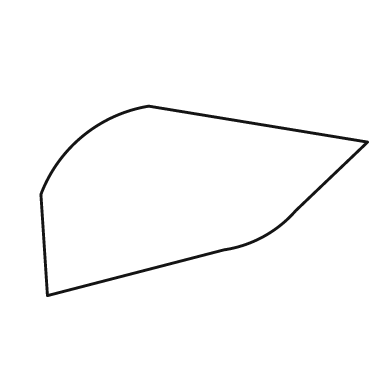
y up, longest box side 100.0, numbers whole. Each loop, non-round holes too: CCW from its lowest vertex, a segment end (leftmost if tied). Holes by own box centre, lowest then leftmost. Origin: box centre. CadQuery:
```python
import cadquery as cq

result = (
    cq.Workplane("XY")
    .moveTo(-48.0, -29.0)
    .lineTo(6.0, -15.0)
    .threePointArc((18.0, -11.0), (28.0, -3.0))
    .lineTo(50.0, 18.0)
    .lineTo(-17.0, 29.0)
    .threePointArc((-37.0, 20.0), (-50.0, 2.0))
    .close()
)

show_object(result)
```